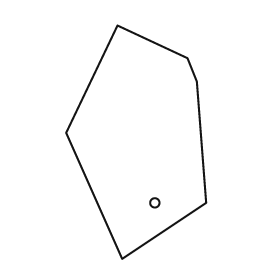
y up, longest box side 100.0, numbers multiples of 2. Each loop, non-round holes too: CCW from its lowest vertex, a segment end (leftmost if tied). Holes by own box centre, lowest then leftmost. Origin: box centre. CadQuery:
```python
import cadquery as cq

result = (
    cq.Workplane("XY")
    .moveTo(-6.0, -50.0)
    .lineTo(30.0, -26.0)
    .lineTo(26.0, 26.0)
    .lineTo(22.0, 36.0)
    .lineTo(-8.0, 50.0)
    .lineTo(-30.0, 4.0)
    .close()
    .moveTo(8.0, -26.0)
    .circle(2.0)
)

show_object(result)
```